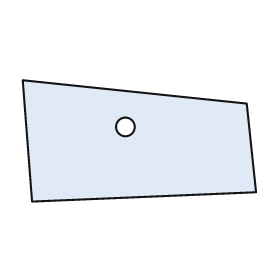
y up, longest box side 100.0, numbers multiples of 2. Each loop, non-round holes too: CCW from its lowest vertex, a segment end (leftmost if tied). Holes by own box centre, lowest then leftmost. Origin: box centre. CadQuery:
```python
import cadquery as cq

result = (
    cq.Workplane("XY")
    .moveTo(-46.0, -26.0)
    .lineTo(50.0, -22.0)
    .lineTo(46.0, 16.0)
    .lineTo(-50.0, 26.0)
    .close()
    .moveTo(-6.0, 6.0)
    .circle(4.0)
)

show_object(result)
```